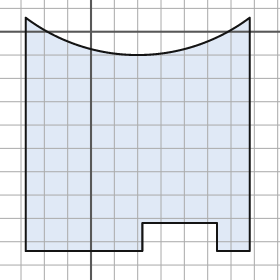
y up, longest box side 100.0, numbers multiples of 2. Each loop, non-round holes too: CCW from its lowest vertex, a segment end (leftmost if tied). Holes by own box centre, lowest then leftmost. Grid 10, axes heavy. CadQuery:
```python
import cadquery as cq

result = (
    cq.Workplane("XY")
    .moveTo(-28.0, -94.0)
    .lineTo(22.0, -94.0)
    .lineTo(22.0, -82.0)
    .lineTo(54.0, -82.0)
    .lineTo(54.0, -94.0)
    .lineTo(68.0, -94.0)
    .lineTo(68.0, 6.0)
    .threePointArc((20.0, -10.0), (-28.0, 6.0))
    .close()
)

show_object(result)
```